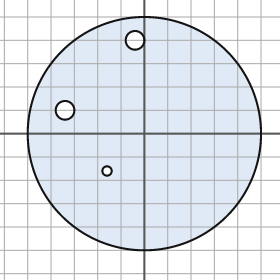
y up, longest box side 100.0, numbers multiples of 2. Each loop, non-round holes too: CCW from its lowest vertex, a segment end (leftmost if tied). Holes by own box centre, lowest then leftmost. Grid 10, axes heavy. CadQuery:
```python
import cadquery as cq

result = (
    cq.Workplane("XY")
    .moveTo(0.0, 0.0)
    .circle(50.0)
    .moveTo(-16.0, -16.0)
    .circle(2.0)
    .moveTo(-34.0, 10.0)
    .circle(4.0)
    .moveTo(-4.0, 40.0)
    .circle(4.0)
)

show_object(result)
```